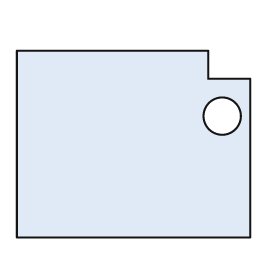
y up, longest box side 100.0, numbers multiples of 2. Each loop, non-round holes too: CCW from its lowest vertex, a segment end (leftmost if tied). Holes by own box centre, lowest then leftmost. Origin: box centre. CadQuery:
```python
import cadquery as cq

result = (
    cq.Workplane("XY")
    .moveTo(-50.0, -40.0)
    .lineTo(50.0, -40.0)
    .lineTo(50.0, 28.0)
    .lineTo(32.0, 28.0)
    .lineTo(32.0, 40.0)
    .lineTo(-50.0, 40.0)
    .close()
    .moveTo(38.0, 12.0)
    .circle(8.0)
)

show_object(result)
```